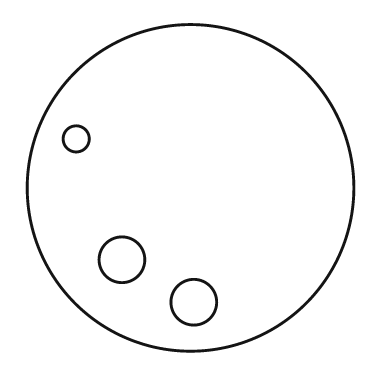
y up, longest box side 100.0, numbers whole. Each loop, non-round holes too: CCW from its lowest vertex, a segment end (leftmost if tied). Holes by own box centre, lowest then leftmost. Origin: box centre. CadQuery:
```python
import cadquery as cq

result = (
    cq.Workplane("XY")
    .moveTo(0.0, 0.0)
    .circle(50.0)
    .moveTo(1.0, -35.0)
    .circle(7.0)
    .moveTo(-21.0, -22.0)
    .circle(7.0)
    .moveTo(-35.0, 15.0)
    .circle(4.0)
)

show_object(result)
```